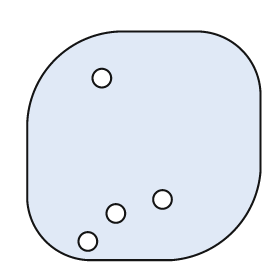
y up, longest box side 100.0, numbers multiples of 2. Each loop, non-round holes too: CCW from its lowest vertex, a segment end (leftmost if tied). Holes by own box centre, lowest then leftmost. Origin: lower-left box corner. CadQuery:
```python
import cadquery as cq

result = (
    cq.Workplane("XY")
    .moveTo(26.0, 0.0)
    .lineTo(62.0, 0.0)
    .threePointArc((88.0, 12.0), (100.0, 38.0))
    .lineTo(100.0, 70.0)
    .threePointArc((92.0, 90.0), (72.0, 98.0))
    .lineTo(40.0, 98.0)
    .threePointArc((12.0, 86.0), (0.0, 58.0))
    .lineTo(0.0, 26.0)
    .threePointArc((8.0, 8.0), (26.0, 0.0))
    .close()
    .moveTo(26.0, 8.0)
    .circle(4.0)
    .moveTo(38.0, 20.0)
    .circle(4.0)
    .moveTo(58.0, 26.0)
    .circle(4.0)
    .moveTo(32.0, 78.0)
    .circle(4.0)
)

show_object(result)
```